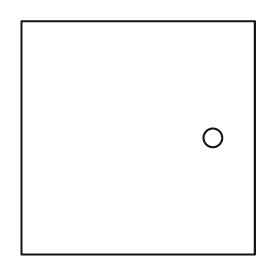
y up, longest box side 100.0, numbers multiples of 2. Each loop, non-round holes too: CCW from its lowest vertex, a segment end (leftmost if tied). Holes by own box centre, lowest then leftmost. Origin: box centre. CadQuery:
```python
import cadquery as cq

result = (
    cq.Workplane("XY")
    .moveTo(-50.0, -50.0)
    .lineTo(50.0, -50.0)
    .lineTo(50.0, 50.0)
    .lineTo(-50.0, 50.0)
    .close()
    .moveTo(32.0, 0.0)
    .circle(4.0)
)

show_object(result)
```